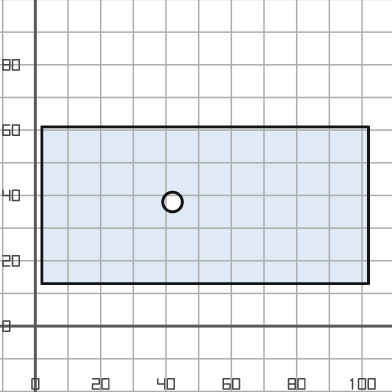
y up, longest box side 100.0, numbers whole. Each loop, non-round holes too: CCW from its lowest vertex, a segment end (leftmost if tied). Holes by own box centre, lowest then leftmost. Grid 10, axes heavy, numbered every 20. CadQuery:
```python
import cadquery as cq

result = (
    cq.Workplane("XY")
    .moveTo(2.0, 13.0)
    .lineTo(102.0, 13.0)
    .lineTo(102.0, 61.0)
    .lineTo(2.0, 61.0)
    .close()
    .moveTo(42.0, 38.0)
    .circle(3.0)
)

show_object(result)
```